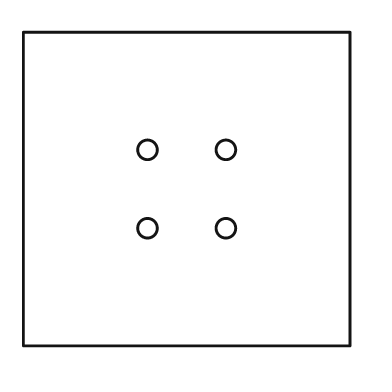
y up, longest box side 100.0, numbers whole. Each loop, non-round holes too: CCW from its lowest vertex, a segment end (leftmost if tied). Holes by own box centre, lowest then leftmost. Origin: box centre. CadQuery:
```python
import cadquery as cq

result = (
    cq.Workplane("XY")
    .moveTo(-50.0, -48.0)
    .lineTo(50.0, -48.0)
    .lineTo(50.0, 48.0)
    .lineTo(-50.0, 48.0)
    .close()
    .moveTo(-12.0, -12.0)
    .circle(3.0)
    .moveTo(12.0, -12.0)
    .circle(3.0)
    .moveTo(-12.0, 12.0)
    .circle(3.0)
    .moveTo(12.0, 12.0)
    .circle(3.0)
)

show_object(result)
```